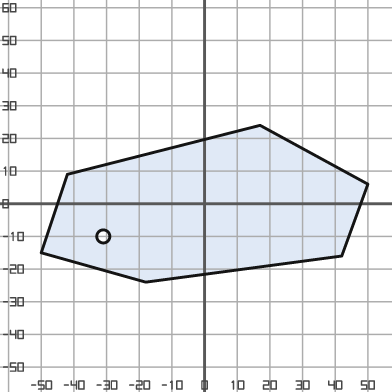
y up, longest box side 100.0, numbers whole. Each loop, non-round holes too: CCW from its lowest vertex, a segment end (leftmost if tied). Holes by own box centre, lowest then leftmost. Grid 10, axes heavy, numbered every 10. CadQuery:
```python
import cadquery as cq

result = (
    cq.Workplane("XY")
    .moveTo(-18.0, -24.0)
    .lineTo(42.0, -16.0)
    .lineTo(50.0, 6.0)
    .lineTo(17.0, 24.0)
    .lineTo(-42.0, 9.0)
    .lineTo(-50.0, -15.0)
    .close()
    .moveTo(-31.0, -10.0)
    .circle(2.0)
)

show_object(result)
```